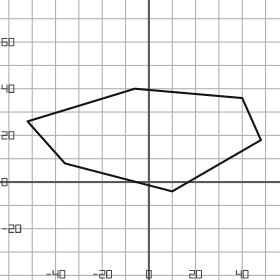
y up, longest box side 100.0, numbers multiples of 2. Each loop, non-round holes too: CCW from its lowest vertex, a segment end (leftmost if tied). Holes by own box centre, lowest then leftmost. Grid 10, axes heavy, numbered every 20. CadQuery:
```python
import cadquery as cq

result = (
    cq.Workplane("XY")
    .moveTo(10.0, -4.0)
    .lineTo(48.0, 18.0)
    .lineTo(40.0, 36.0)
    .lineTo(-6.0, 40.0)
    .lineTo(-52.0, 26.0)
    .lineTo(-36.0, 8.0)
    .close()
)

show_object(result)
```